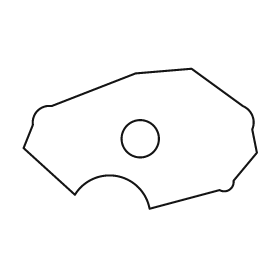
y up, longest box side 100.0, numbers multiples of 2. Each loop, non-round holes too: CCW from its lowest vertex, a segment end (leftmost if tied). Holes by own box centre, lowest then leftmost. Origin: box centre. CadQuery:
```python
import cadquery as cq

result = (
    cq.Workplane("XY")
    .moveTo(4.0, -30.0)
    .lineTo(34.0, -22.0)
    .threePointArc((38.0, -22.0), (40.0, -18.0))
    .lineTo(50.0, -6.0)
    .lineTo(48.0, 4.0)
    .threePointArc((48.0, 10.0), (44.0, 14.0))
    .lineTo(22.0, 30.0)
    .lineTo(-2.0, 28.0)
    .lineTo(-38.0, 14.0)
    .threePointArc((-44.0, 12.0), (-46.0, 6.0))
    .lineTo(-50.0, -4.0)
    .lineTo(-28.0, -24.0)
    .threePointArc((-10.0, -16.0), (4.0, -30.0))
    .close()
    .moveTo(0.0, 0.0)
    .circle(8.0)
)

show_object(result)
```